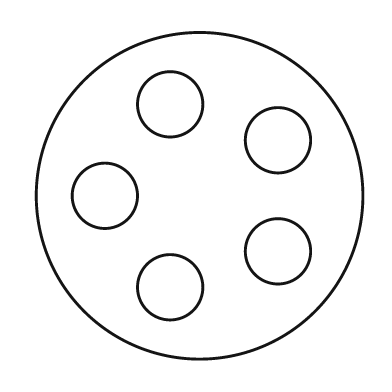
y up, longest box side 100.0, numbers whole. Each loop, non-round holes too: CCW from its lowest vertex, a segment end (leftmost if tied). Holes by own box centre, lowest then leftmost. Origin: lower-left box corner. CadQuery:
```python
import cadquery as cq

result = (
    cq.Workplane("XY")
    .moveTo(50.0, 50.0)
    .circle(50.0)
    .moveTo(41.0, 22.0)
    .circle(10.0)
    .moveTo(74.0, 33.0)
    .circle(10.0)
    .moveTo(21.0, 50.0)
    .circle(10.0)
    .moveTo(74.0, 67.0)
    .circle(10.0)
    .moveTo(41.0, 78.0)
    .circle(10.0)
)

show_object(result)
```